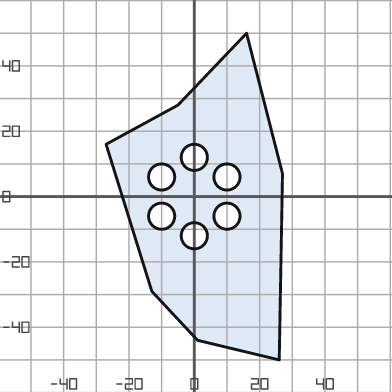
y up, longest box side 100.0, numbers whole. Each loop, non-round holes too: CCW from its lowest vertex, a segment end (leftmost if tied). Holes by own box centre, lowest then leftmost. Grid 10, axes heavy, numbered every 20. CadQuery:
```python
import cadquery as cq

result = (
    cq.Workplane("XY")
    .moveTo(26.0, -50.0)
    .lineTo(27.0, 7.0)
    .lineTo(16.0, 50.0)
    .lineTo(-5.0, 28.0)
    .lineTo(-27.0, 16.0)
    .lineTo(-13.0, -29.0)
    .lineTo(1.0, -44.0)
    .close()
    .moveTo(0.0, -12.0)
    .circle(4.0)
    .moveTo(-10.0, -6.0)
    .circle(4.0)
    .moveTo(10.0, -6.0)
    .circle(4.0)
    .moveTo(-10.0, 6.0)
    .circle(4.0)
    .moveTo(10.0, 6.0)
    .circle(4.0)
    .moveTo(0.0, 12.0)
    .circle(4.0)
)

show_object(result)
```